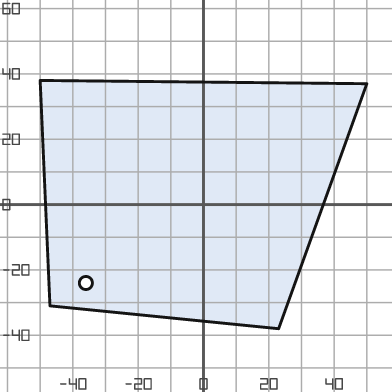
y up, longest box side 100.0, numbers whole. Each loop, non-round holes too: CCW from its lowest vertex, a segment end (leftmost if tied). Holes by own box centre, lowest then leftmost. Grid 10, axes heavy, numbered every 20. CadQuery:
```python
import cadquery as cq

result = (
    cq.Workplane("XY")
    .moveTo(23.0, -38.0)
    .lineTo(50.0, 37.0)
    .lineTo(-50.0, 38.0)
    .lineTo(-47.0, -31.0)
    .close()
    .moveTo(-36.0, -24.0)
    .circle(2.0)
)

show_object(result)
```